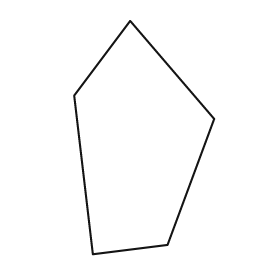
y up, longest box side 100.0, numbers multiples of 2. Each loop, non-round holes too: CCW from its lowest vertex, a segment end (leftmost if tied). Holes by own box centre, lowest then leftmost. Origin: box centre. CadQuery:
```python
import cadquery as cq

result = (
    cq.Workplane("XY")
    .moveTo(-22.0, -50.0)
    .lineTo(10.0, -46.0)
    .lineTo(30.0, 8.0)
    .lineTo(-6.0, 50.0)
    .lineTo(-30.0, 18.0)
    .close()
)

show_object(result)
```